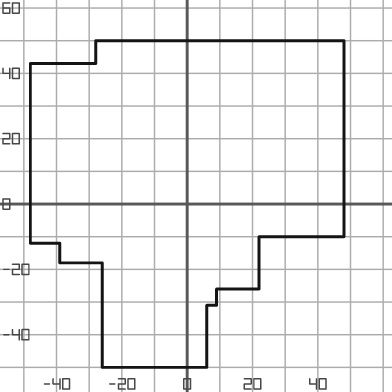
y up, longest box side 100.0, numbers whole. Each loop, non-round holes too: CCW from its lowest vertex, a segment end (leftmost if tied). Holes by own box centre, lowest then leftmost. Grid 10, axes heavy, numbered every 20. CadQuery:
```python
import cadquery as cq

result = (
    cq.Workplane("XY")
    .moveTo(-26.0, -50.0)
    .lineTo(6.0, -50.0)
    .lineTo(6.0, -31.0)
    .lineTo(9.0, -31.0)
    .lineTo(9.0, -26.0)
    .lineTo(22.0, -26.0)
    .lineTo(22.0, -10.0)
    .lineTo(48.0, -10.0)
    .lineTo(48.0, 50.0)
    .lineTo(-28.0, 50.0)
    .lineTo(-28.0, 43.0)
    .lineTo(-48.0, 43.0)
    .lineTo(-48.0, -12.0)
    .lineTo(-39.0, -12.0)
    .lineTo(-39.0, -18.0)
    .lineTo(-26.0, -18.0)
    .close()
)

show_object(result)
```